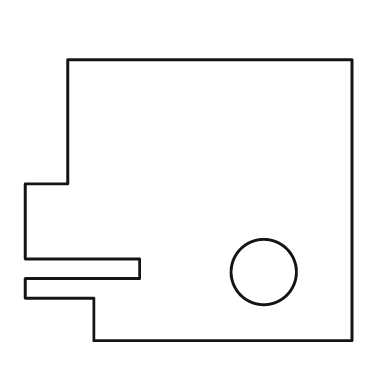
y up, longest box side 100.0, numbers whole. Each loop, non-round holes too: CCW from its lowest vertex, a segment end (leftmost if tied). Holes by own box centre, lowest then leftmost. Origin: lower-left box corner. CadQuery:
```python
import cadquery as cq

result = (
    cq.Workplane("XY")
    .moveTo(21.0, 0.0)
    .lineTo(100.0, 0.0)
    .lineTo(100.0, 86.0)
    .lineTo(13.0, 86.0)
    .lineTo(13.0, 48.0)
    .lineTo(0.0, 48.0)
    .lineTo(0.0, 25.0)
    .lineTo(35.0, 25.0)
    .lineTo(35.0, 19.0)
    .lineTo(0.0, 19.0)
    .lineTo(0.0, 13.0)
    .lineTo(21.0, 13.0)
    .close()
    .moveTo(73.0, 21.0)
    .circle(10.0)
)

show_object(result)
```